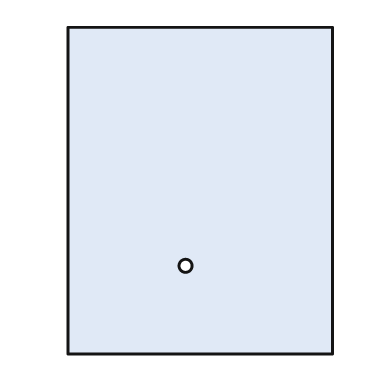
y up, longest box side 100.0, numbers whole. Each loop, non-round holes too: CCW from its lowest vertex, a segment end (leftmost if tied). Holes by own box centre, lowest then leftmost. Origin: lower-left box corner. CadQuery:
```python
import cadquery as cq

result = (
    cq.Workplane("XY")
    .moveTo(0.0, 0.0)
    .lineTo(81.0, 0.0)
    .lineTo(81.0, 100.0)
    .lineTo(0.0, 100.0)
    .close()
    .moveTo(36.0, 27.0)
    .circle(2.0)
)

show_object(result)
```